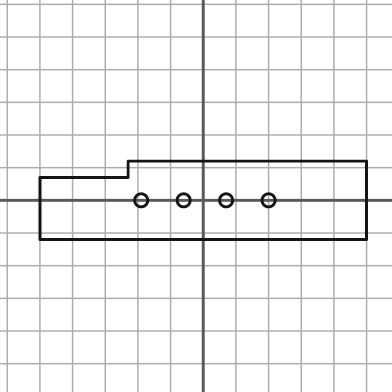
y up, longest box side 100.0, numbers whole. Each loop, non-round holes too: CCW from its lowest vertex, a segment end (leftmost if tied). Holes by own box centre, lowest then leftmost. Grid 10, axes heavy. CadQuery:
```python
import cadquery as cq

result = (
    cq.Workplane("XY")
    .moveTo(-50.0, -12.0)
    .lineTo(50.0, -12.0)
    .lineTo(50.0, 12.0)
    .lineTo(-23.0, 12.0)
    .lineTo(-23.0, 7.0)
    .lineTo(-50.0, 7.0)
    .close()
    .moveTo(-19.0, 0.0)
    .circle(2.0)
    .moveTo(-6.0, 0.0)
    .circle(2.0)
    .moveTo(7.0, 0.0)
    .circle(2.0)
    .moveTo(20.0, 0.0)
    .circle(2.0)
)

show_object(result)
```